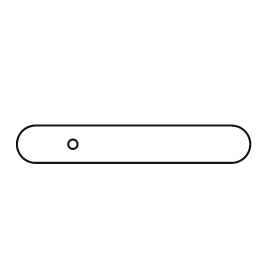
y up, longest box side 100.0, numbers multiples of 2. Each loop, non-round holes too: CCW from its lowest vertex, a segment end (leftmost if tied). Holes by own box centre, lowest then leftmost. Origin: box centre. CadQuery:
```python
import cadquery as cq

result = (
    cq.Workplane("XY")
    .moveTo(-42.0, -8.0)
    .lineTo(42.0, -8.0)
    .threePointArc((50.0, 0.0), (42.0, 8.0))
    .lineTo(-42.0, 8.0)
    .threePointArc((-50.0, 0.0), (-42.0, -8.0))
    .close()
    .moveTo(-26.0, 0.0)
    .circle(2.0)
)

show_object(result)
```